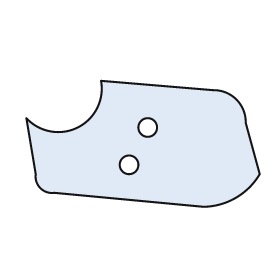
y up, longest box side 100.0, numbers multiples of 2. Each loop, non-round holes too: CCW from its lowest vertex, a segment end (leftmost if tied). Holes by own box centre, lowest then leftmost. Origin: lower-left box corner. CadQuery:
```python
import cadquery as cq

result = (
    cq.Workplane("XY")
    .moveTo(76.0, 0.0)
    .threePointArc((90.0, 4.0), (100.0, 14.0))
    .lineTo(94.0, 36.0)
    .threePointArc((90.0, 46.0), (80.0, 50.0))
    .lineTo(32.0, 54.0)
    .threePointArc((22.0, 34.0), (0.0, 38.0))
    .lineTo(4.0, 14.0)
    .threePointArc((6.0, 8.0), (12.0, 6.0))
    .close()
    .moveTo(44.0, 18.0)
    .circle(4.0)
    .moveTo(52.0, 34.0)
    .circle(4.0)
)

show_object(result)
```